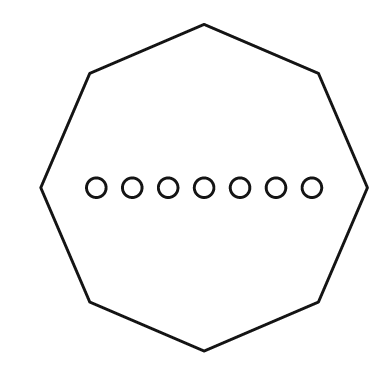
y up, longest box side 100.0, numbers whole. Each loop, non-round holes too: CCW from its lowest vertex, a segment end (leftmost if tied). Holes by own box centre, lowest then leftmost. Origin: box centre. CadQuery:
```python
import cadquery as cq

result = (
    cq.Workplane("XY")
    .moveTo(0.0, -50.0)
    .lineTo(35.0, -35.0)
    .lineTo(50.0, 0.0)
    .lineTo(35.0, 35.0)
    .lineTo(0.0, 50.0)
    .lineTo(-35.0, 35.0)
    .lineTo(-50.0, 0.0)
    .lineTo(-35.0, -35.0)
    .close()
    .moveTo(-33.0, 0.0)
    .circle(3.0)
    .moveTo(-22.0, 0.0)
    .circle(3.0)
    .moveTo(-11.0, 0.0)
    .circle(3.0)
    .moveTo(0.0, 0.0)
    .circle(3.0)
    .moveTo(11.0, 0.0)
    .circle(3.0)
    .moveTo(22.0, 0.0)
    .circle(3.0)
    .moveTo(33.0, 0.0)
    .circle(3.0)
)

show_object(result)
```